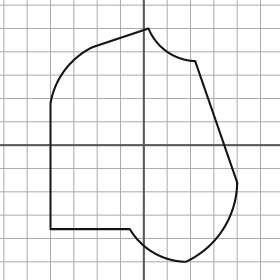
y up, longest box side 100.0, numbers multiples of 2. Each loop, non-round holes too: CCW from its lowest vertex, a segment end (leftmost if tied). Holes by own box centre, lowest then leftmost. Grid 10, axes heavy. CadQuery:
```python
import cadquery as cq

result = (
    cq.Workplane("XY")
    .moveTo(18.0, -50.0)
    .threePointArc((34.0, -36.0), (40.0, -16.0))
    .lineTo(22.0, 36.0)
    .threePointArc((10.0, 40.0), (2.0, 50.0))
    .lineTo(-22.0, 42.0)
    .threePointArc((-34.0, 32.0), (-40.0, 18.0))
    .lineTo(-40.0, -36.0)
    .lineTo(-6.0, -36.0)
    .threePointArc((4.0, -46.0), (18.0, -50.0))
    .close()
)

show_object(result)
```